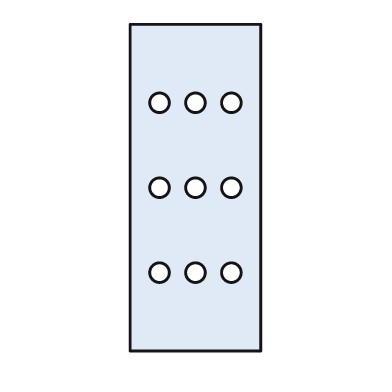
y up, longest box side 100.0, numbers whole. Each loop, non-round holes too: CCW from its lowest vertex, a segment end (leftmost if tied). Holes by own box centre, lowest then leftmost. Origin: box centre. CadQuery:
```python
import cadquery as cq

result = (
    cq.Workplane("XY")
    .moveTo(-20.0, -50.0)
    .lineTo(20.0, -50.0)
    .lineTo(20.0, 50.0)
    .lineTo(-20.0, 50.0)
    .close()
    .moveTo(-11.0, -26.0)
    .circle(3.0)
    .moveTo(0.0, -26.0)
    .circle(3.0)
    .moveTo(11.0, -26.0)
    .circle(3.0)
    .moveTo(-11.0, 0.0)
    .circle(3.0)
    .moveTo(0.0, 0.0)
    .circle(3.0)
    .moveTo(11.0, 0.0)
    .circle(3.0)
    .moveTo(-11.0, 26.0)
    .circle(3.0)
    .moveTo(0.0, 26.0)
    .circle(3.0)
    .moveTo(11.0, 26.0)
    .circle(3.0)
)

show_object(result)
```